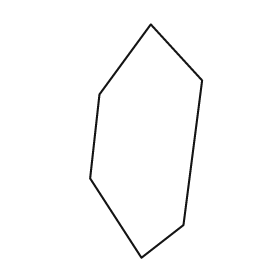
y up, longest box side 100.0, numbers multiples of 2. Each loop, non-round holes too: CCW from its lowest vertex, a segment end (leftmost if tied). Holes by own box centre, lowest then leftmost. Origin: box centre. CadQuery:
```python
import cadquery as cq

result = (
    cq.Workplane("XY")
    .moveTo(-2.0, -50.0)
    .lineTo(16.0, -36.0)
    .lineTo(24.0, 26.0)
    .lineTo(2.0, 50.0)
    .lineTo(-20.0, 20.0)
    .lineTo(-24.0, -16.0)
    .close()
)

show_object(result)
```